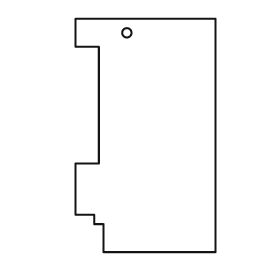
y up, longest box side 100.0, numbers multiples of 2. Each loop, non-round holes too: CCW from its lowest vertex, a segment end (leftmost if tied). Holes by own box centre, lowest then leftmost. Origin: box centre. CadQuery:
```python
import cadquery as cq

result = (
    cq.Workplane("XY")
    .moveTo(-18.0, -50.0)
    .lineTo(30.0, -50.0)
    .lineTo(30.0, 50.0)
    .lineTo(-30.0, 50.0)
    .lineTo(-30.0, 38.0)
    .lineTo(-20.0, 38.0)
    .lineTo(-20.0, -12.0)
    .lineTo(-30.0, -12.0)
    .lineTo(-30.0, -34.0)
    .lineTo(-22.0, -34.0)
    .lineTo(-22.0, -38.0)
    .lineTo(-18.0, -38.0)
    .close()
    .moveTo(-8.0, 44.0)
    .circle(2.0)
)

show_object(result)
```